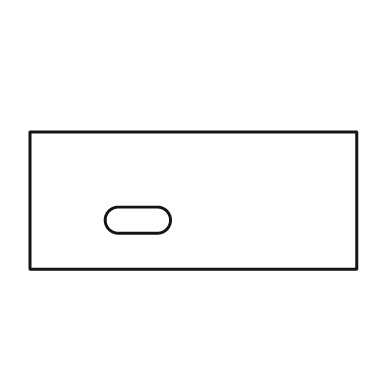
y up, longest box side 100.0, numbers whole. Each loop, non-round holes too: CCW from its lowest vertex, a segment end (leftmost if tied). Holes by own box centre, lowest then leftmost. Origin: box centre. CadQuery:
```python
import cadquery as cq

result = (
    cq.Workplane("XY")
    .moveTo(-50.0, -21.0)
    .lineTo(50.0, -21.0)
    .lineTo(50.0, 21.0)
    .lineTo(-50.0, 21.0)
    .close()
    .moveTo(-23.0, -10.0)
    .lineTo(-11.0, -10.0)
    .threePointArc((-7.0, -6.0), (-11.0, -2.0))
    .lineTo(-23.0, -2.0)
    .threePointArc((-27.0, -6.0), (-23.0, -10.0))
    .close()
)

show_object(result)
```